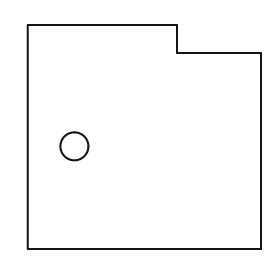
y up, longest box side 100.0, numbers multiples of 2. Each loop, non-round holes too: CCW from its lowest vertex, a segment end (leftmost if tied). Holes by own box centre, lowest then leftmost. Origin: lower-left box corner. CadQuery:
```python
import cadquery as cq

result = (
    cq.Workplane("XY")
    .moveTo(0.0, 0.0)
    .lineTo(100.0, 0.0)
    .lineTo(100.0, 84.0)
    .lineTo(64.0, 84.0)
    .lineTo(64.0, 96.0)
    .lineTo(0.0, 96.0)
    .close()
    .moveTo(20.0, 44.0)
    .circle(6.0)
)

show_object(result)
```